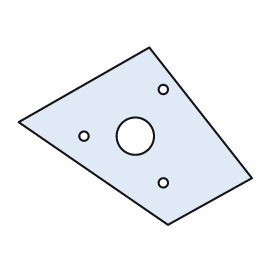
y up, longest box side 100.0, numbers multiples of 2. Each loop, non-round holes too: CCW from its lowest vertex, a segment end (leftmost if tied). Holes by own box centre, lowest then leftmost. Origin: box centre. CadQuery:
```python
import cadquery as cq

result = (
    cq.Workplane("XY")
    .moveTo(14.0, -38.0)
    .lineTo(50.0, -18.0)
    .lineTo(6.0, 38.0)
    .lineTo(-50.0, 6.0)
    .close()
    .moveTo(12.0, -20.0)
    .circle(2.0)
    .moveTo(-22.0, 0.0)
    .circle(2.0)
    .moveTo(0.0, 0.0)
    .circle(8.0)
    .moveTo(12.0, 20.0)
    .circle(2.0)
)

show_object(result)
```